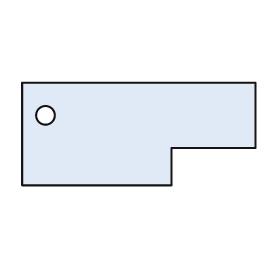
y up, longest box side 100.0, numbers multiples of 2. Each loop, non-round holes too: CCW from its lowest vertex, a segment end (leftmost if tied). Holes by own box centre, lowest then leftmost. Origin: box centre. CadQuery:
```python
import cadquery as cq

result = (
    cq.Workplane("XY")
    .moveTo(-50.0, -22.0)
    .lineTo(14.0, -22.0)
    .lineTo(14.0, -6.0)
    .lineTo(50.0, -6.0)
    .lineTo(50.0, 22.0)
    .lineTo(-50.0, 22.0)
    .close()
    .moveTo(-40.0, 8.0)
    .circle(4.0)
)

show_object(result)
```